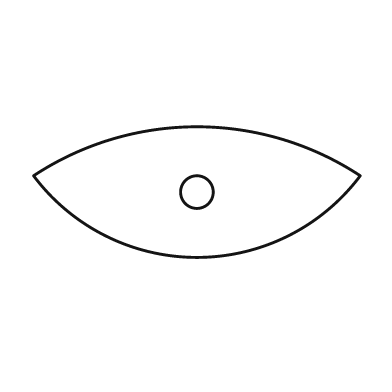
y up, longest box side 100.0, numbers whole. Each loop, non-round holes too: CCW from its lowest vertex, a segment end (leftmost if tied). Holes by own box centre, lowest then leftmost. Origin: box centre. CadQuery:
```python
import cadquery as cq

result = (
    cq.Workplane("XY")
    .moveTo(-50.0, 5.0)
    .threePointArc((0.0, -20.0), (50.0, 5.0))
    .threePointArc((0.0, 20.0), (-50.0, 5.0))
    .close()
    .moveTo(0.0, 0.0)
    .circle(5.0)
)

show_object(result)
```